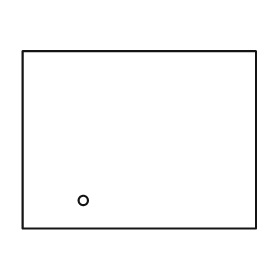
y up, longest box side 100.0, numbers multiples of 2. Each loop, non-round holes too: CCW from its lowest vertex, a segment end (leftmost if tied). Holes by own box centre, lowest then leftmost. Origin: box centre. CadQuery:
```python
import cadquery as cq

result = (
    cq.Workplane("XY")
    .moveTo(-50.0, -38.0)
    .lineTo(50.0, -38.0)
    .lineTo(50.0, 38.0)
    .lineTo(-50.0, 38.0)
    .close()
    .moveTo(-24.0, -26.0)
    .circle(2.0)
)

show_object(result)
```